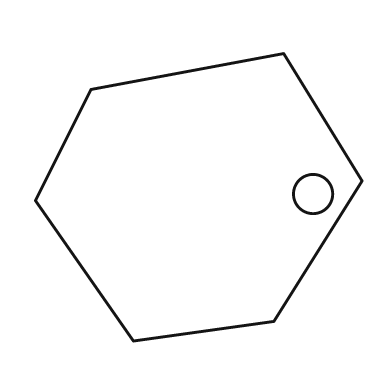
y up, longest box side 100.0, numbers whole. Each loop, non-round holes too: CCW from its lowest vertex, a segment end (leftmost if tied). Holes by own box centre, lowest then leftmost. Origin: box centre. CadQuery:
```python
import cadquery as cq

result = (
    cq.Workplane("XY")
    .moveTo(-20.0, -44.0)
    .lineTo(23.0, -38.0)
    .lineTo(50.0, 5.0)
    .lineTo(26.0, 44.0)
    .lineTo(-33.0, 33.0)
    .lineTo(-50.0, -1.0)
    .close()
    .moveTo(35.0, 1.0)
    .circle(6.0)
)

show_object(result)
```